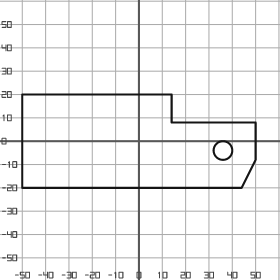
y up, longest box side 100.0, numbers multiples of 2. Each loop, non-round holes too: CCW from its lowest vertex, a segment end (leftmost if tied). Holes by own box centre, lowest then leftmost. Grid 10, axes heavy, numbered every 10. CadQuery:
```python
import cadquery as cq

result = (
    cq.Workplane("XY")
    .moveTo(-50.0, -20.0)
    .lineTo(44.0, -20.0)
    .lineTo(50.0, -8.0)
    .lineTo(50.0, 8.0)
    .lineTo(14.0, 8.0)
    .lineTo(14.0, 20.0)
    .lineTo(-50.0, 20.0)
    .close()
    .moveTo(36.0, -4.0)
    .circle(4.0)
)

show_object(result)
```